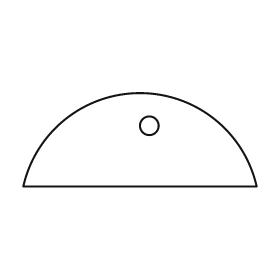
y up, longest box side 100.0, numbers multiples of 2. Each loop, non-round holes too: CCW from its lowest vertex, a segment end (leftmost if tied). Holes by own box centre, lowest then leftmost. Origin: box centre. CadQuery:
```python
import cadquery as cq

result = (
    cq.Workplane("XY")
    .moveTo(-50.0, -20.0)
    .lineTo(50.0, -20.0)
    .threePointArc((0.0, 20.0), (-50.0, -20.0))
    .close()
    .moveTo(4.0, 6.0)
    .circle(4.0)
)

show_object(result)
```